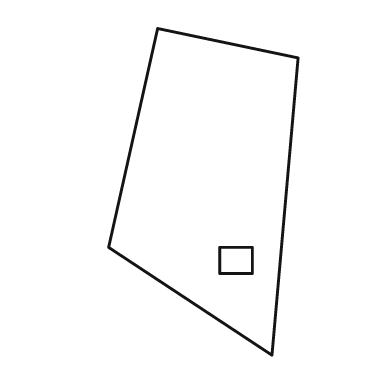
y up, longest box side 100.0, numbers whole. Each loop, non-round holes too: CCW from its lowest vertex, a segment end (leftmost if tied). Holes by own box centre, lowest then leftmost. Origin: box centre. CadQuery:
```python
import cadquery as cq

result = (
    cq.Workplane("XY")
    .moveTo(21.0, -50.0)
    .lineTo(29.0, 41.0)
    .lineTo(-14.0, 50.0)
    .lineTo(-29.0, -17.0)
    .close()
    .moveTo(5.0, -25.0)
    .lineTo(15.0, -25.0)
    .lineTo(15.0, -17.0)
    .lineTo(5.0, -17.0)
    .close()
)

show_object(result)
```